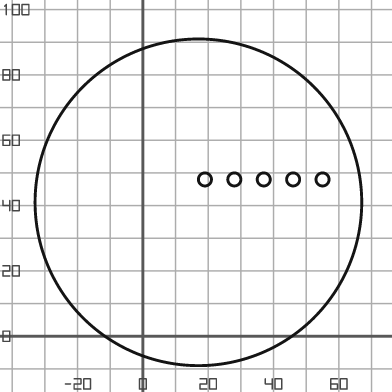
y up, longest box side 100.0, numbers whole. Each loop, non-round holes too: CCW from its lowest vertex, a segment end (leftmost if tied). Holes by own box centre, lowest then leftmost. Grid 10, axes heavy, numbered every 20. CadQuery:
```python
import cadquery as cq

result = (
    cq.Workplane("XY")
    .moveTo(17.0, 41.0)
    .circle(50.0)
    .moveTo(19.0, 48.0)
    .circle(2.0)
    .moveTo(28.0, 48.0)
    .circle(2.0)
    .moveTo(37.0, 48.0)
    .circle(2.0)
    .moveTo(46.0, 48.0)
    .circle(2.0)
    .moveTo(55.0, 48.0)
    .circle(2.0)
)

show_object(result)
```